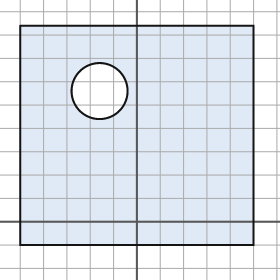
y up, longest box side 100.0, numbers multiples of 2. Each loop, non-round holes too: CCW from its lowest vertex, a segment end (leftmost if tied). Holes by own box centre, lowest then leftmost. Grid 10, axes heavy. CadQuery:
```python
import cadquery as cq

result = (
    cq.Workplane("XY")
    .moveTo(-50.0, -10.0)
    .lineTo(50.0, -10.0)
    .lineTo(50.0, 84.0)
    .lineTo(-50.0, 84.0)
    .close()
    .moveTo(-16.0, 56.0)
    .circle(12.0)
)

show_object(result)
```